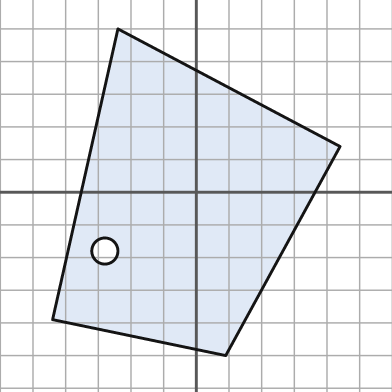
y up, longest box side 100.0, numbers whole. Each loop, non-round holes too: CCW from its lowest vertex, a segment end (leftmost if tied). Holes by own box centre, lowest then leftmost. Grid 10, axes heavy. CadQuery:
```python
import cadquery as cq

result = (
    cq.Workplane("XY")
    .moveTo(9.0, -50.0)
    .lineTo(44.0, 14.0)
    .lineTo(-24.0, 50.0)
    .lineTo(-44.0, -39.0)
    .close()
    .moveTo(-28.0, -18.0)
    .circle(4.0)
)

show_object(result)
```